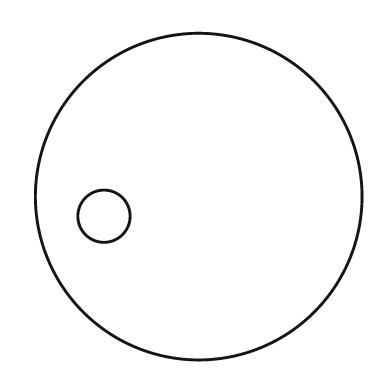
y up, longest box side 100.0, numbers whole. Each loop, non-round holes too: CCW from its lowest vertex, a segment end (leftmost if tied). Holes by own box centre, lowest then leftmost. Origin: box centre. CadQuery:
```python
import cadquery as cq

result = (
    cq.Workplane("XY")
    .moveTo(0.0, 0.0)
    .circle(50.0)
    .moveTo(-29.0, -6.0)
    .circle(8.0)
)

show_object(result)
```